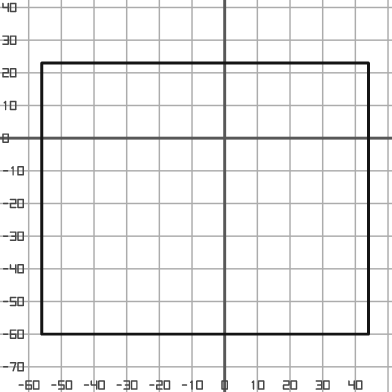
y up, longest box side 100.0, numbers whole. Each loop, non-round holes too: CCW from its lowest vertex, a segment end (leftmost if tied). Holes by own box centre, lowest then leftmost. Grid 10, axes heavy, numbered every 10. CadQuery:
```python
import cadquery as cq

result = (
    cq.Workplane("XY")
    .moveTo(-56.0, -60.0)
    .lineTo(44.0, -60.0)
    .lineTo(44.0, 23.0)
    .lineTo(-56.0, 23.0)
    .close()
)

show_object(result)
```